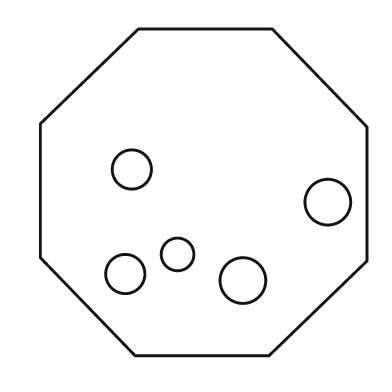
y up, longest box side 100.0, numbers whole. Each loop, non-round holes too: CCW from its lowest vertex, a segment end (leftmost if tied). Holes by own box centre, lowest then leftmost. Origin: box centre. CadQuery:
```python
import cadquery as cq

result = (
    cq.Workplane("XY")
    .moveTo(-21.0, -50.0)
    .lineTo(20.0, -50.0)
    .lineTo(50.0, -21.0)
    .lineTo(50.0, 20.0)
    .lineTo(21.0, 50.0)
    .lineTo(-20.0, 50.0)
    .lineTo(-50.0, 21.0)
    .lineTo(-50.0, -20.0)
    .close()
    .moveTo(12.0, -27.0)
    .circle(7.0)
    .moveTo(-24.0, -25.0)
    .circle(6.0)
    .moveTo(-8.0, -19.0)
    .circle(5.0)
    .moveTo(38.0, -3.0)
    .circle(7.0)
    .moveTo(-22.0, 7.0)
    .circle(6.0)
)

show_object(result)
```